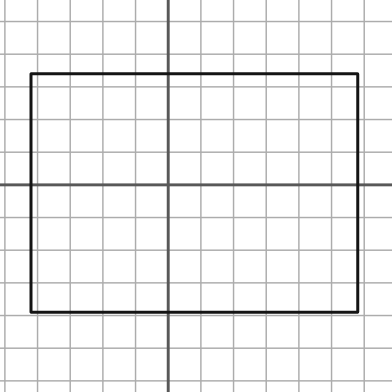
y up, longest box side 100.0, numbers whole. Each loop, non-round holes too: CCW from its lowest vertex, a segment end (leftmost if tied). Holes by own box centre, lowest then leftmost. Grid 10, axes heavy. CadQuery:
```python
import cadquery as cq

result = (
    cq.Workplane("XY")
    .moveTo(-42.0, -39.0)
    .lineTo(58.0, -39.0)
    .lineTo(58.0, 34.0)
    .lineTo(-42.0, 34.0)
    .close()
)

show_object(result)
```